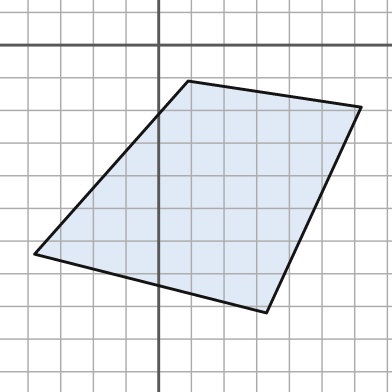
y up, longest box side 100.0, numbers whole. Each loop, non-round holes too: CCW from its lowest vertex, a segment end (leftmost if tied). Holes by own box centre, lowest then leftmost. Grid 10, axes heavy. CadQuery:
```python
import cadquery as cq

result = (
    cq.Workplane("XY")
    .moveTo(33.0, -82.0)
    .lineTo(62.0, -19.0)
    .lineTo(9.0, -11.0)
    .lineTo(-38.0, -64.0)
    .close()
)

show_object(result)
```